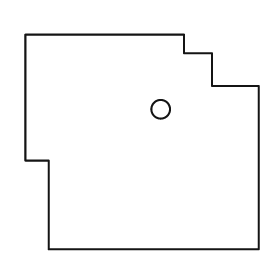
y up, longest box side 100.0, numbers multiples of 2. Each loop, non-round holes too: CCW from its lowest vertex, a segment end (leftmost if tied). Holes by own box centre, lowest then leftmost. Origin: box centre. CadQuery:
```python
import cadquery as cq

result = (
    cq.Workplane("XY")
    .moveTo(-40.0, -46.0)
    .lineTo(50.0, -46.0)
    .lineTo(50.0, 24.0)
    .lineTo(30.0, 24.0)
    .lineTo(30.0, 38.0)
    .lineTo(18.0, 38.0)
    .lineTo(18.0, 46.0)
    .lineTo(-50.0, 46.0)
    .lineTo(-50.0, -8.0)
    .lineTo(-40.0, -8.0)
    .close()
    .moveTo(8.0, 14.0)
    .circle(4.0)
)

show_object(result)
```